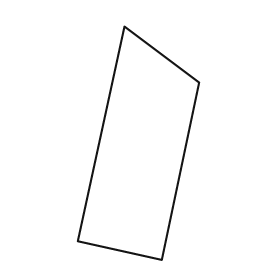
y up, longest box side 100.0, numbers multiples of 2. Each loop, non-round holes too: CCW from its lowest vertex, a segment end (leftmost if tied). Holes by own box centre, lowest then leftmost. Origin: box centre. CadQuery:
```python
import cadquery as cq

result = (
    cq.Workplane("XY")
    .moveTo(10.0, -50.0)
    .lineTo(26.0, 26.0)
    .lineTo(-6.0, 50.0)
    .lineTo(-26.0, -42.0)
    .close()
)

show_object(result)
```